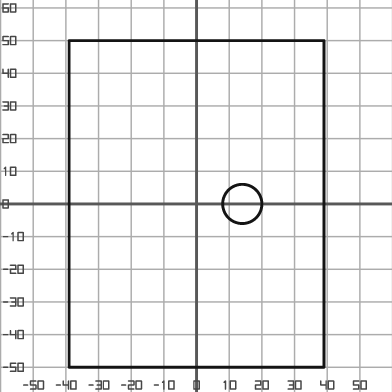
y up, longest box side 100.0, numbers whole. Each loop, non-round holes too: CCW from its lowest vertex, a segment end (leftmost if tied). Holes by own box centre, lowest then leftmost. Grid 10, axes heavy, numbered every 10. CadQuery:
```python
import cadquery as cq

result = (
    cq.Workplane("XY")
    .moveTo(-39.0, -50.0)
    .lineTo(39.0, -50.0)
    .lineTo(39.0, 50.0)
    .lineTo(-39.0, 50.0)
    .close()
    .moveTo(14.0, 0.0)
    .circle(6.0)
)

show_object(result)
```